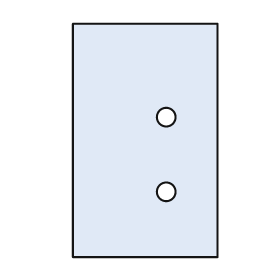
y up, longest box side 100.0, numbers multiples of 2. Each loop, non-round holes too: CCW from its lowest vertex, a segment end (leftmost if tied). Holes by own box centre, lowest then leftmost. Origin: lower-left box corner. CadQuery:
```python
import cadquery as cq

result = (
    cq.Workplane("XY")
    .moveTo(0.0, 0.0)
    .lineTo(62.0, 0.0)
    .lineTo(62.0, 100.0)
    .lineTo(0.0, 100.0)
    .close()
    .moveTo(40.0, 28.0)
    .circle(4.0)
    .moveTo(40.0, 60.0)
    .circle(4.0)
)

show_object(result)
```